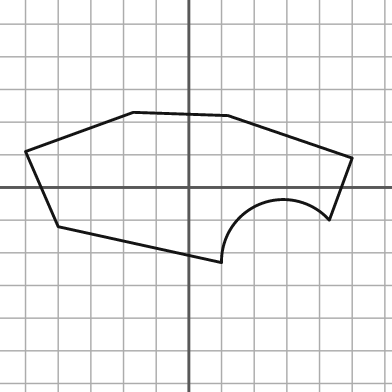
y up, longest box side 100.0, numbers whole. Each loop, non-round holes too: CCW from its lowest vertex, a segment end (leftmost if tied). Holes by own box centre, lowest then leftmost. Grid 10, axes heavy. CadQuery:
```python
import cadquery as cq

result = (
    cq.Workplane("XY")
    .moveTo(10.0, -23.0)
    .threePointArc((22.0, -5.0), (43.0, -10.0))
    .lineTo(50.0, 9.0)
    .lineTo(12.0, 22.0)
    .lineTo(-17.0, 23.0)
    .lineTo(-50.0, 11.0)
    .lineTo(-40.0, -12.0)
    .close()
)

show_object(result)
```